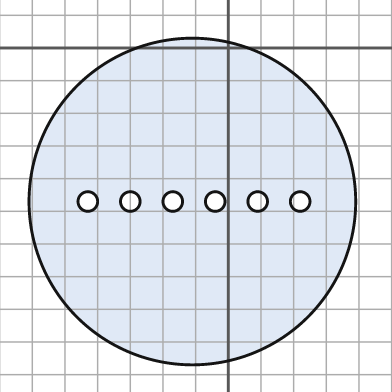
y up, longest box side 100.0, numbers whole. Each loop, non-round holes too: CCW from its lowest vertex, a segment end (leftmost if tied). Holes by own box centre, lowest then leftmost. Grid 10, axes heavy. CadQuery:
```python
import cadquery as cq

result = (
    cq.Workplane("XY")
    .moveTo(-11.0, -47.0)
    .circle(50.0)
    .moveTo(-43.0, -47.0)
    .circle(3.0)
    .moveTo(-30.0, -47.0)
    .circle(3.0)
    .moveTo(-17.0, -47.0)
    .circle(3.0)
    .moveTo(-4.0, -47.0)
    .circle(3.0)
    .moveTo(9.0, -47.0)
    .circle(3.0)
    .moveTo(22.0, -47.0)
    .circle(3.0)
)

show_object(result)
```